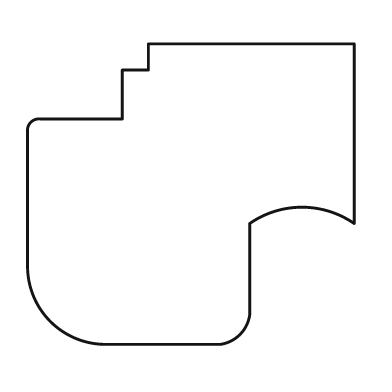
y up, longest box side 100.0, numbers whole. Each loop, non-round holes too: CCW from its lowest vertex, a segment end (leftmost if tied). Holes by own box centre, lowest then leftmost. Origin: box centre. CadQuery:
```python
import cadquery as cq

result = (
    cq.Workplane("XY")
    .moveTo(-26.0, -46.0)
    .lineTo(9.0, -46.0)
    .threePointArc((15.0, -43.0), (18.0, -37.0))
    .lineTo(18.0, -9.0)
    .threePointArc((34.0, -4.0), (50.0, -9.0))
    .lineTo(50.0, 46.0)
    .lineTo(-13.0, 46.0)
    .lineTo(-13.0, 38.0)
    .lineTo(-21.0, 38.0)
    .lineTo(-21.0, 23.0)
    .lineTo(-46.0, 23.0)
    .threePointArc((-49.0, 22.0), (-50.0, 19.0))
    .lineTo(-50.0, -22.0)
    .threePointArc((-43.0, -39.0), (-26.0, -46.0))
    .close()
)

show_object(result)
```